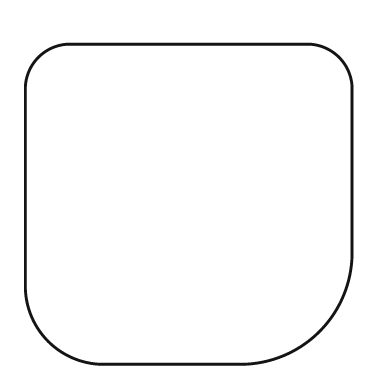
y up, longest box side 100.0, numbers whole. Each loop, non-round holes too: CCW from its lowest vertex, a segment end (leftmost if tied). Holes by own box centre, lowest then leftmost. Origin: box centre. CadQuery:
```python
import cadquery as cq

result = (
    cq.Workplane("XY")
    .moveTo(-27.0, -49.0)
    .lineTo(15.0, -49.0)
    .threePointArc((40.0, -39.0), (50.0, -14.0))
    .lineTo(50.0, 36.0)
    .threePointArc((46.0, 45.0), (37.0, 49.0))
    .lineTo(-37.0, 49.0)
    .threePointArc((-46.0, 45.0), (-50.0, 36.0))
    .lineTo(-50.0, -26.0)
    .threePointArc((-43.0, -42.0), (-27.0, -49.0))
    .close()
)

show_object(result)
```